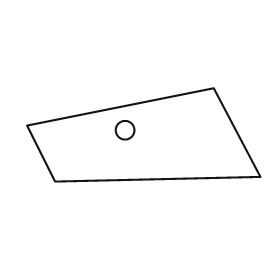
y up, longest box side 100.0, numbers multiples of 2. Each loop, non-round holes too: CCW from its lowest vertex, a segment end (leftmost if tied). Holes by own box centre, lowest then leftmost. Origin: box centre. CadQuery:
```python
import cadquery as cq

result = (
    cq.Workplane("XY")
    .moveTo(-38.0, -20.0)
    .lineTo(50.0, -18.0)
    .lineTo(30.0, 20.0)
    .lineTo(-50.0, 4.0)
    .close()
    .moveTo(-8.0, 2.0)
    .circle(4.0)
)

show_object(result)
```